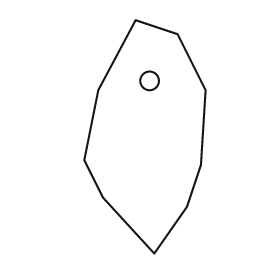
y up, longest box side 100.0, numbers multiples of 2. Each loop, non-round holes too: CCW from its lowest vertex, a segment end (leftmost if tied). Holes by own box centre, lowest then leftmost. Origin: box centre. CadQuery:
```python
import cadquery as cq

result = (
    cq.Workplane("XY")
    .moveTo(4.0, -50.0)
    .lineTo(18.0, -30.0)
    .lineTo(24.0, -12.0)
    .lineTo(26.0, 20.0)
    .lineTo(14.0, 44.0)
    .lineTo(-4.0, 50.0)
    .lineTo(-20.0, 20.0)
    .lineTo(-26.0, -10.0)
    .lineTo(-18.0, -26.0)
    .close()
    .moveTo(2.0, 24.0)
    .circle(4.0)
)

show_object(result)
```